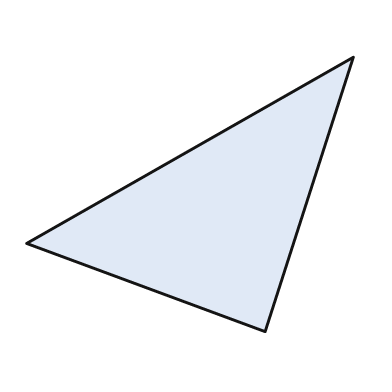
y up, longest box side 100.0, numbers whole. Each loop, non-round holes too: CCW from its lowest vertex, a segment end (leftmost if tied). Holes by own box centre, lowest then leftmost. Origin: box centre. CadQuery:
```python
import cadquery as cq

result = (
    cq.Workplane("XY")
    .moveTo(23.0, -42.0)
    .lineTo(50.0, 42.0)
    .lineTo(-50.0, -15.0)
    .close()
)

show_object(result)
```